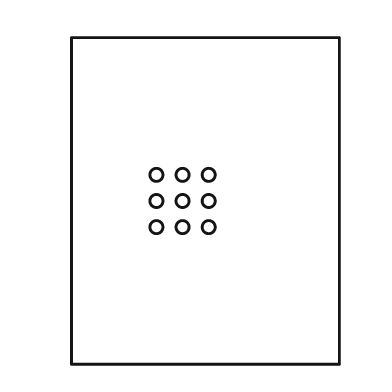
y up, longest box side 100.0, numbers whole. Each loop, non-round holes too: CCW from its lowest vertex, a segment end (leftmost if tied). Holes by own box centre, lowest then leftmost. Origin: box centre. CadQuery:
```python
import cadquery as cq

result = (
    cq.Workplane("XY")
    .moveTo(-41.0, -50.0)
    .lineTo(41.0, -50.0)
    .lineTo(41.0, 50.0)
    .lineTo(-41.0, 50.0)
    .close()
    .moveTo(-15.0, -8.0)
    .circle(2.0)
    .moveTo(-7.0, -8.0)
    .circle(2.0)
    .moveTo(1.0, -8.0)
    .circle(2.0)
    .moveTo(-15.0, 0.0)
    .circle(2.0)
    .moveTo(-7.0, 0.0)
    .circle(2.0)
    .moveTo(1.0, 0.0)
    .circle(2.0)
    .moveTo(-15.0, 8.0)
    .circle(2.0)
    .moveTo(-7.0, 8.0)
    .circle(2.0)
    .moveTo(1.0, 8.0)
    .circle(2.0)
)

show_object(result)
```